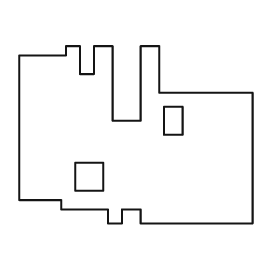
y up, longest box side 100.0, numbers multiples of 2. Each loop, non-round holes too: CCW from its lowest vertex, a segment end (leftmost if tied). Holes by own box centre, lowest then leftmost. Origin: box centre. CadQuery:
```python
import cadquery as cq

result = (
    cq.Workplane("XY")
    .moveTo(-12.0, -38.0)
    .lineTo(-6.0, -38.0)
    .lineTo(-6.0, -32.0)
    .lineTo(2.0, -32.0)
    .lineTo(2.0, -38.0)
    .lineTo(50.0, -38.0)
    .lineTo(50.0, 18.0)
    .lineTo(10.0, 18.0)
    .lineTo(10.0, 38.0)
    .lineTo(2.0, 38.0)
    .lineTo(2.0, 6.0)
    .lineTo(-10.0, 6.0)
    .lineTo(-10.0, 38.0)
    .lineTo(-18.0, 38.0)
    .lineTo(-18.0, 26.0)
    .lineTo(-24.0, 26.0)
    .lineTo(-24.0, 38.0)
    .lineTo(-30.0, 38.0)
    .lineTo(-30.0, 34.0)
    .lineTo(-50.0, 34.0)
    .lineTo(-50.0, -28.0)
    .lineTo(-32.0, -28.0)
    .lineTo(-32.0, -32.0)
    .lineTo(-12.0, -32.0)
    .close()
    .moveTo(-26.0, -24.0)
    .lineTo(-14.0, -24.0)
    .lineTo(-14.0, -12.0)
    .lineTo(-26.0, -12.0)
    .close()
    .moveTo(12.0, 0.0)
    .lineTo(20.0, 0.0)
    .lineTo(20.0, 12.0)
    .lineTo(12.0, 12.0)
    .close()
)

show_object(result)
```